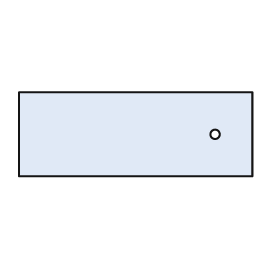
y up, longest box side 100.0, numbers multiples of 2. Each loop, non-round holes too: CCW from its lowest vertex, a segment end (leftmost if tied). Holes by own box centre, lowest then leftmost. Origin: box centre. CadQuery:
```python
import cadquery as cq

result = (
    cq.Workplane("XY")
    .moveTo(-50.0, -18.0)
    .lineTo(50.0, -18.0)
    .lineTo(50.0, 18.0)
    .lineTo(-50.0, 18.0)
    .close()
    .moveTo(34.0, 0.0)
    .circle(2.0)
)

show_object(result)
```